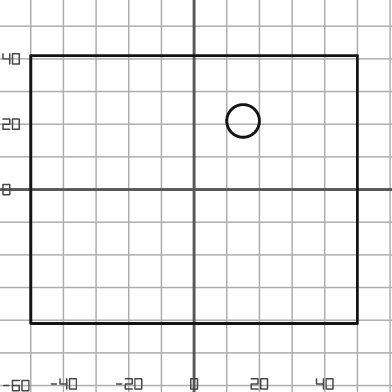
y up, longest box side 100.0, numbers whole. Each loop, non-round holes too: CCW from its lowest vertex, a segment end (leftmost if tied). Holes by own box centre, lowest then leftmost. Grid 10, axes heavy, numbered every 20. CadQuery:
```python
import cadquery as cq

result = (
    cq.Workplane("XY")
    .moveTo(-50.0, -41.0)
    .lineTo(50.0, -41.0)
    .lineTo(50.0, 41.0)
    .lineTo(-50.0, 41.0)
    .close()
    .moveTo(15.0, 21.0)
    .circle(5.0)
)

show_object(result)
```